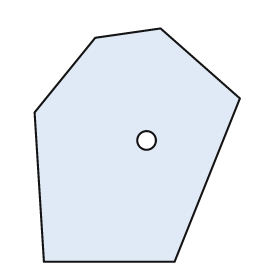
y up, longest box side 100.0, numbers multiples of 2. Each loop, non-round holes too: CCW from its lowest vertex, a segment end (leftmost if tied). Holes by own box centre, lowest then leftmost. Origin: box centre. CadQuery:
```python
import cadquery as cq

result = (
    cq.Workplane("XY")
    .moveTo(-40.0, -50.0)
    .lineTo(16.0, -50.0)
    .lineTo(44.0, 20.0)
    .lineTo(10.0, 50.0)
    .lineTo(-18.0, 46.0)
    .lineTo(-44.0, 14.0)
    .close()
    .moveTo(4.0, 2.0)
    .circle(4.0)
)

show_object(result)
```